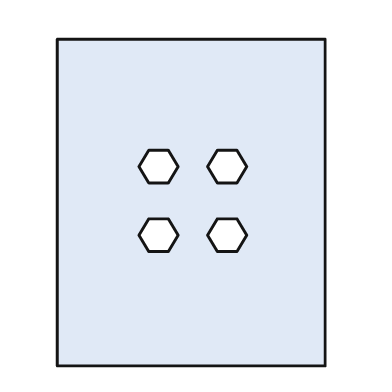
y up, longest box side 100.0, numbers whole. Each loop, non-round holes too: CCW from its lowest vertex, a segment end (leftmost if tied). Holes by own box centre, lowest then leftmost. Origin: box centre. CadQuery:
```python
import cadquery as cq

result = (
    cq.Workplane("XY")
    .moveTo(-41.0, -50.0)
    .lineTo(41.0, -50.0)
    .lineTo(41.0, 50.0)
    .lineTo(-41.0, 50.0)
    .close()
    .moveTo(-13.0, -15.0)
    .lineTo(-7.0, -15.0)
    .lineTo(-4.0, -10.0)
    .lineTo(-7.0, -5.0)
    .lineTo(-13.0, -5.0)
    .lineTo(-16.0, -10.0)
    .close()
    .moveTo(8.0, -15.0)
    .lineTo(14.0, -15.0)
    .lineTo(17.0, -10.0)
    .lineTo(14.0, -5.0)
    .lineTo(8.0, -5.0)
    .lineTo(5.0, -10.0)
    .close()
    .moveTo(-13.0, 6.0)
    .lineTo(-7.0, 6.0)
    .lineTo(-4.0, 11.0)
    .lineTo(-7.0, 16.0)
    .lineTo(-13.0, 16.0)
    .lineTo(-16.0, 11.0)
    .close()
    .moveTo(8.0, 6.0)
    .lineTo(14.0, 6.0)
    .lineTo(17.0, 11.0)
    .lineTo(14.0, 16.0)
    .lineTo(8.0, 16.0)
    .lineTo(5.0, 11.0)
    .close()
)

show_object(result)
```